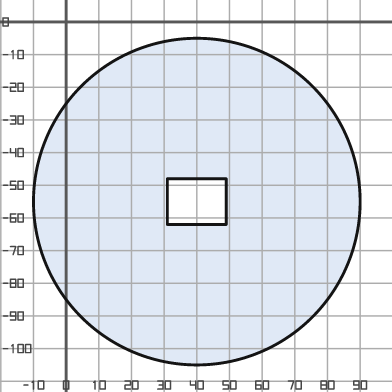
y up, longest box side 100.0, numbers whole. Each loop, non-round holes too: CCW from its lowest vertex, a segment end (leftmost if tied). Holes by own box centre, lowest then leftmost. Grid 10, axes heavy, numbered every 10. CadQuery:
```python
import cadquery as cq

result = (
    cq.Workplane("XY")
    .moveTo(40.0, -55.0)
    .circle(50.0)
    .moveTo(31.0, -62.0)
    .lineTo(49.0, -62.0)
    .lineTo(49.0, -48.0)
    .lineTo(31.0, -48.0)
    .close()
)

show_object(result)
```